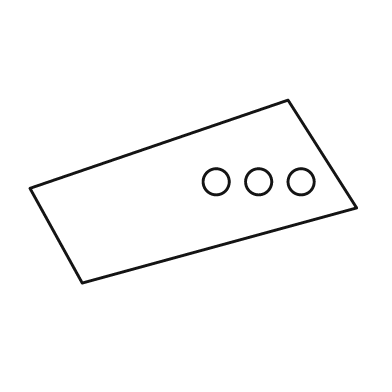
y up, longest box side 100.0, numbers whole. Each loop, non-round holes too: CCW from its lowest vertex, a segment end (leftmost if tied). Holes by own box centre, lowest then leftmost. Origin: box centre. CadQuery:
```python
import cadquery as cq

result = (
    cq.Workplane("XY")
    .moveTo(-34.0, -28.0)
    .lineTo(50.0, -5.0)
    .lineTo(29.0, 28.0)
    .lineTo(-50.0, 1.0)
    .close()
    .moveTo(7.0, 3.0)
    .circle(4.0)
    .moveTo(20.0, 3.0)
    .circle(4.0)
    .moveTo(33.0, 3.0)
    .circle(4.0)
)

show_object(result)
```